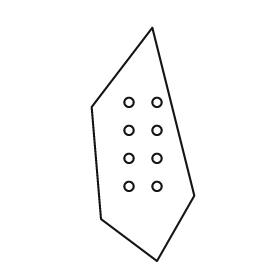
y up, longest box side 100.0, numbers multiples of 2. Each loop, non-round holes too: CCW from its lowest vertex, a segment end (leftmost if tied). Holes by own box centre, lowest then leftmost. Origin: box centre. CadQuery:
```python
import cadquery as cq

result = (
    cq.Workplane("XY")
    .moveTo(6.0, -50.0)
    .lineTo(22.0, -22.0)
    .lineTo(4.0, 50.0)
    .lineTo(-22.0, 16.0)
    .lineTo(-18.0, -32.0)
    .close()
    .moveTo(-6.0, -18.0)
    .circle(2.0)
    .moveTo(6.0, -18.0)
    .circle(2.0)
    .moveTo(-6.0, -6.0)
    .circle(2.0)
    .moveTo(6.0, -6.0)
    .circle(2.0)
    .moveTo(-6.0, 6.0)
    .circle(2.0)
    .moveTo(6.0, 6.0)
    .circle(2.0)
    .moveTo(-6.0, 18.0)
    .circle(2.0)
    .moveTo(6.0, 18.0)
    .circle(2.0)
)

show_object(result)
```